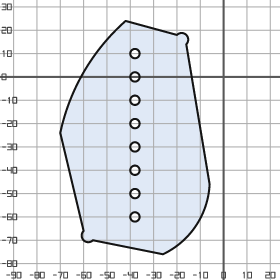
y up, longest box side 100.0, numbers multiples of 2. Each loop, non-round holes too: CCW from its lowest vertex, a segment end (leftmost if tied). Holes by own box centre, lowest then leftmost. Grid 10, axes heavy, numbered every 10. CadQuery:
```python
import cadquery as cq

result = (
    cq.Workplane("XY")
    .moveTo(-26.0, -76.0)
    .threePointArc((-12.0, -64.0), (-6.0, -46.0))
    .lineTo(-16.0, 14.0)
    .threePointArc((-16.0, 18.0), (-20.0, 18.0))
    .lineTo(-42.0, 24.0)
    .threePointArc((-60.0, 2.0), (-70.0, -24.0))
    .lineTo(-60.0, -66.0)
    .threePointArc((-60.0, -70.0), (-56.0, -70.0))
    .close()
    .moveTo(-38.0, -60.0)
    .circle(2.0)
    .moveTo(-38.0, -50.0)
    .circle(2.0)
    .moveTo(-38.0, -40.0)
    .circle(2.0)
    .moveTo(-38.0, -30.0)
    .circle(2.0)
    .moveTo(-38.0, -20.0)
    .circle(2.0)
    .moveTo(-38.0, -10.0)
    .circle(2.0)
    .moveTo(-38.0, 0.0)
    .circle(2.0)
    .moveTo(-38.0, 10.0)
    .circle(2.0)
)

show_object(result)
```